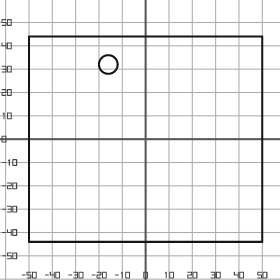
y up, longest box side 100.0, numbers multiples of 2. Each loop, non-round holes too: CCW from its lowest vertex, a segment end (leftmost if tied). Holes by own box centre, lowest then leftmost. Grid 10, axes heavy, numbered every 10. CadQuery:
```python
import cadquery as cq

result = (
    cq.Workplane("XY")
    .moveTo(-50.0, -44.0)
    .lineTo(50.0, -44.0)
    .lineTo(50.0, 44.0)
    .lineTo(-50.0, 44.0)
    .close()
    .moveTo(-16.0, 32.0)
    .circle(4.0)
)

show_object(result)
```